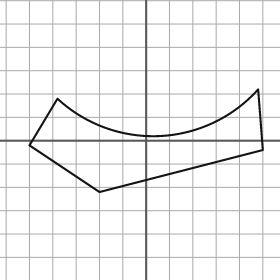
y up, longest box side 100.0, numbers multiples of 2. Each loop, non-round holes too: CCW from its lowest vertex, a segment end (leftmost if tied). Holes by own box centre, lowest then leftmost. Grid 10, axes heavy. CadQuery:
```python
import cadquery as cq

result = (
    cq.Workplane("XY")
    .moveTo(-20.0, -22.0)
    .lineTo(50.0, -4.0)
    .lineTo(48.0, 22.0)
    .threePointArc((6.0, 2.0), (-38.0, 18.0))
    .lineTo(-50.0, -2.0)
    .close()
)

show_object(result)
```